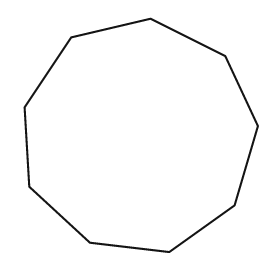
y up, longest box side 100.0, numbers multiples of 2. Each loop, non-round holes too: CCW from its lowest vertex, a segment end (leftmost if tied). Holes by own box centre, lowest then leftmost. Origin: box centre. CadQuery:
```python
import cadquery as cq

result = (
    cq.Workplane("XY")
    .moveTo(12.0, -50.0)
    .lineTo(40.0, -30.0)
    .lineTo(50.0, 4.0)
    .lineTo(36.0, 34.0)
    .lineTo(4.0, 50.0)
    .lineTo(-30.0, 42.0)
    .lineTo(-50.0, 12.0)
    .lineTo(-48.0, -22.0)
    .lineTo(-22.0, -46.0)
    .close()
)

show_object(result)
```